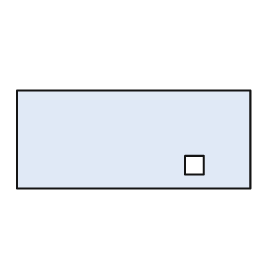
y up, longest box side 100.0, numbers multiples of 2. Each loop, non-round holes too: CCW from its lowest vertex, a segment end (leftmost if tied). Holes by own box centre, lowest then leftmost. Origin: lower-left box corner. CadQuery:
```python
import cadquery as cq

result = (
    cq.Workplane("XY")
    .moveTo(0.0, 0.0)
    .lineTo(100.0, 0.0)
    .lineTo(100.0, 42.0)
    .lineTo(0.0, 42.0)
    .close()
    .moveTo(72.0, 6.0)
    .lineTo(80.0, 6.0)
    .lineTo(80.0, 14.0)
    .lineTo(72.0, 14.0)
    .close()
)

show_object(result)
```